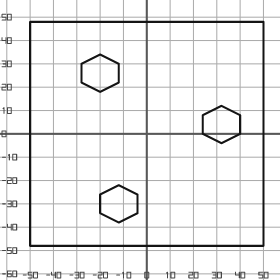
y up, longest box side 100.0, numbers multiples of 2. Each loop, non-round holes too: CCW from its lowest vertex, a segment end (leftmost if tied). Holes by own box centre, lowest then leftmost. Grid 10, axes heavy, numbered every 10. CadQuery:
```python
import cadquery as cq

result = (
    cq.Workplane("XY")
    .moveTo(-50.0, -48.0)
    .lineTo(50.0, -48.0)
    .lineTo(50.0, 48.0)
    .lineTo(-50.0, 48.0)
    .close()
    .moveTo(-12.0, -38.0)
    .lineTo(-4.0, -34.0)
    .lineTo(-4.0, -26.0)
    .lineTo(-12.0, -22.0)
    .lineTo(-20.0, -26.0)
    .lineTo(-20.0, -34.0)
    .close()
    .moveTo(32.0, -4.0)
    .lineTo(40.0, 0.0)
    .lineTo(40.0, 8.0)
    .lineTo(32.0, 12.0)
    .lineTo(24.0, 8.0)
    .lineTo(24.0, 0.0)
    .close()
    .moveTo(-20.0, 18.0)
    .lineTo(-12.0, 22.0)
    .lineTo(-12.0, 30.0)
    .lineTo(-20.0, 34.0)
    .lineTo(-28.0, 30.0)
    .lineTo(-28.0, 22.0)
    .close()
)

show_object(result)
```